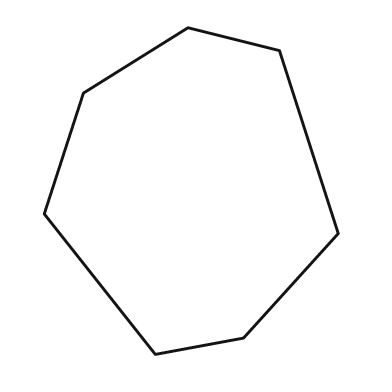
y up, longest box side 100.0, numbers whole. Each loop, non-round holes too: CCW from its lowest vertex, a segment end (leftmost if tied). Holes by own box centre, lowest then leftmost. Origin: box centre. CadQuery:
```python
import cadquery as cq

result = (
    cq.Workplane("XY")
    .moveTo(-11.0, -50.0)
    .lineTo(16.0, -45.0)
    .lineTo(45.0, -13.0)
    .lineTo(27.0, 43.0)
    .lineTo(-1.0, 50.0)
    .lineTo(-33.0, 30.0)
    .lineTo(-45.0, -7.0)
    .close()
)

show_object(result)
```